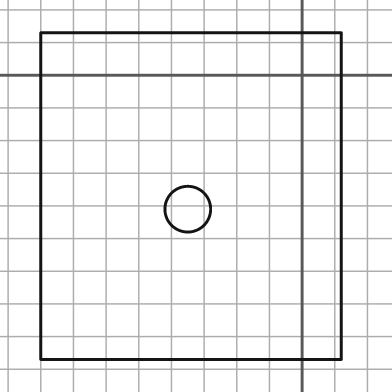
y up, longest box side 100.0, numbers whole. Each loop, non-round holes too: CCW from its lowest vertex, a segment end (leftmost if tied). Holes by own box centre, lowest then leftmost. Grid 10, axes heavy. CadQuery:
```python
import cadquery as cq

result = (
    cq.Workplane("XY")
    .moveTo(-80.0, -87.0)
    .lineTo(12.0, -87.0)
    .lineTo(12.0, 13.0)
    .lineTo(-80.0, 13.0)
    .close()
    .moveTo(-35.0, -41.0)
    .circle(7.0)
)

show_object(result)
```